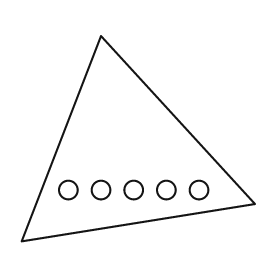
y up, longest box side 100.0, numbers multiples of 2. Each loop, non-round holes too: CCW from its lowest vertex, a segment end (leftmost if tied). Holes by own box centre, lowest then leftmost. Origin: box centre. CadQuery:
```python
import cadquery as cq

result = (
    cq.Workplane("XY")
    .moveTo(-50.0, -44.0)
    .lineTo(50.0, -28.0)
    .lineTo(-16.0, 44.0)
    .close()
    .moveTo(-30.0, -22.0)
    .circle(4.0)
    .moveTo(-16.0, -22.0)
    .circle(4.0)
    .moveTo(-2.0, -22.0)
    .circle(4.0)
    .moveTo(12.0, -22.0)
    .circle(4.0)
    .moveTo(26.0, -22.0)
    .circle(4.0)
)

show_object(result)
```